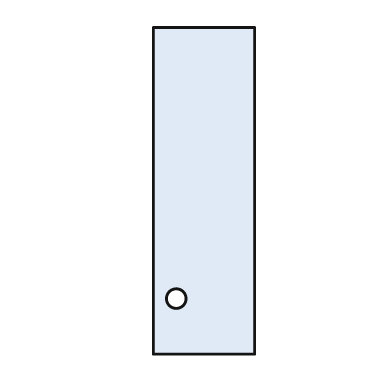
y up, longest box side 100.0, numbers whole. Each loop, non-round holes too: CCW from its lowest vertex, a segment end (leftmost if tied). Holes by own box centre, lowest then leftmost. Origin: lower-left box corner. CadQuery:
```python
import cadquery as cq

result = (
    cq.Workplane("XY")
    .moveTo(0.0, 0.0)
    .lineTo(31.0, 0.0)
    .lineTo(31.0, 100.0)
    .lineTo(0.0, 100.0)
    .close()
    .moveTo(7.0, 17.0)
    .circle(3.0)
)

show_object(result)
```